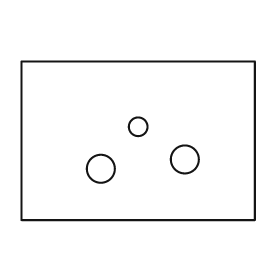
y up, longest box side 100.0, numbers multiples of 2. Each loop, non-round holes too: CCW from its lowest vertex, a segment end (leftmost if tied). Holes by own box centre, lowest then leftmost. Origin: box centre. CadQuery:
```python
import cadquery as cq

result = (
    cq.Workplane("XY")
    .moveTo(-50.0, -34.0)
    .lineTo(50.0, -34.0)
    .lineTo(50.0, 34.0)
    .lineTo(-50.0, 34.0)
    .close()
    .moveTo(-16.0, -12.0)
    .circle(6.0)
    .moveTo(20.0, -8.0)
    .circle(6.0)
    .moveTo(0.0, 6.0)
    .circle(4.0)
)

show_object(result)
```